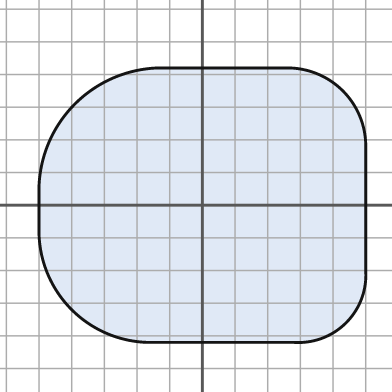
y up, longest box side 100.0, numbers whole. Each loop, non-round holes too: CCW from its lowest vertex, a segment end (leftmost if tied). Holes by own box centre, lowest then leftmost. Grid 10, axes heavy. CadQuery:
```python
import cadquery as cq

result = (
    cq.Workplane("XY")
    .moveTo(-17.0, -42.0)
    .lineTo(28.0, -42.0)
    .threePointArc((44.0, -36.0), (50.0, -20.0))
    .lineTo(50.0, 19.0)
    .threePointArc((43.0, 35.0), (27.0, 42.0))
    .lineTo(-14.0, 42.0)
    .threePointArc((-39.0, 31.0), (-50.0, 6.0))
    .lineTo(-50.0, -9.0)
    .threePointArc((-40.0, -32.0), (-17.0, -42.0))
    .close()
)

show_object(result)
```